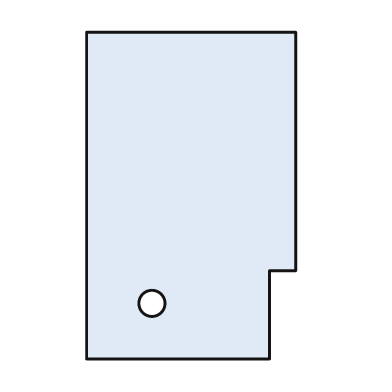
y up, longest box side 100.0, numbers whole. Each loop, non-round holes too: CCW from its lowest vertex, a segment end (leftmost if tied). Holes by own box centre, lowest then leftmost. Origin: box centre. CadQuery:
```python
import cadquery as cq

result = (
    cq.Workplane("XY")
    .moveTo(-32.0, -50.0)
    .lineTo(24.0, -50.0)
    .lineTo(24.0, -23.0)
    .lineTo(32.0, -23.0)
    .lineTo(32.0, 50.0)
    .lineTo(-32.0, 50.0)
    .close()
    .moveTo(-12.0, -33.0)
    .circle(4.0)
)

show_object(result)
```